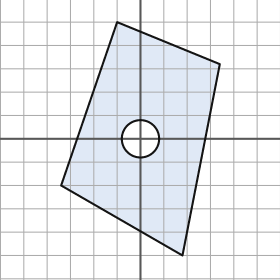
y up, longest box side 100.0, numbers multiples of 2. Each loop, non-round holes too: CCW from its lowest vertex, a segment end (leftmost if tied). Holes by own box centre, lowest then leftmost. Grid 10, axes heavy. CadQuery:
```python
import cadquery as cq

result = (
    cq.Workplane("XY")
    .moveTo(18.0, -50.0)
    .lineTo(34.0, 32.0)
    .lineTo(-10.0, 50.0)
    .lineTo(-34.0, -20.0)
    .close()
    .moveTo(0.0, 0.0)
    .circle(8.0)
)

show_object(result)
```